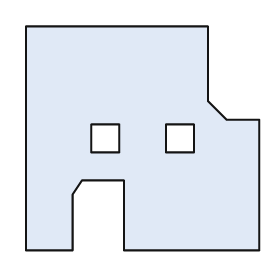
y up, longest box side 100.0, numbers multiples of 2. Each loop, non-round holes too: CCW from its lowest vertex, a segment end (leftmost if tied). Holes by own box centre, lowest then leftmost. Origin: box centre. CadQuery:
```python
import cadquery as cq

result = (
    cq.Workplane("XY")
    .moveTo(-50.0, -48.0)
    .lineTo(-30.0, -48.0)
    .lineTo(-30.0, -24.0)
    .lineTo(-26.0, -18.0)
    .lineTo(-8.0, -18.0)
    .lineTo(-8.0, -48.0)
    .lineTo(50.0, -48.0)
    .lineTo(50.0, 8.0)
    .lineTo(36.0, 8.0)
    .lineTo(28.0, 16.0)
    .lineTo(28.0, 48.0)
    .lineTo(-50.0, 48.0)
    .close()
    .moveTo(-22.0, -6.0)
    .lineTo(-10.0, -6.0)
    .lineTo(-10.0, 6.0)
    .lineTo(-22.0, 6.0)
    .close()
    .moveTo(10.0, -6.0)
    .lineTo(22.0, -6.0)
    .lineTo(22.0, 6.0)
    .lineTo(10.0, 6.0)
    .close()
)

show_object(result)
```